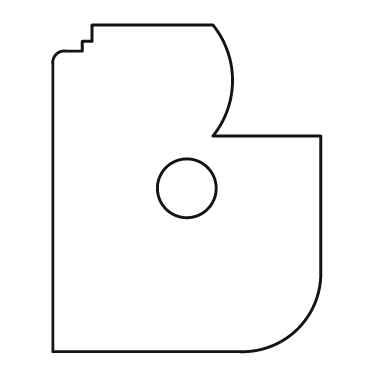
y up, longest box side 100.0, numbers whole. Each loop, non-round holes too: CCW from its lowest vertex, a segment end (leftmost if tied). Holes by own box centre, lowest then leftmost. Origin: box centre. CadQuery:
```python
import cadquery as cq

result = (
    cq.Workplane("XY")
    .moveTo(-41.0, -50.0)
    .lineTo(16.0, -50.0)
    .threePointArc((34.0, -43.0), (41.0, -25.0))
    .lineTo(41.0, 16.0)
    .lineTo(8.0, 16.0)
    .threePointArc((14.0, 33.0), (8.0, 50.0))
    .lineTo(-29.0, 50.0)
    .lineTo(-29.0, 45.0)
    .lineTo(-32.0, 45.0)
    .lineTo(-32.0, 42.0)
    .lineTo(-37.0, 42.0)
    .threePointArc((-40.0, 41.0), (-41.0, 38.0))
    .close()
    .moveTo(0.0, 0.0)
    .circle(9.0)
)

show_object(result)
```